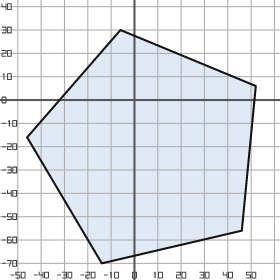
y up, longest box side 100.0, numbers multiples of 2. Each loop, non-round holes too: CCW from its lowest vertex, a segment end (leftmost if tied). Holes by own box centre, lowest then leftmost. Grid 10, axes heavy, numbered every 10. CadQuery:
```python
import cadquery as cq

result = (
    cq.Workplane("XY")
    .moveTo(-14.0, -70.0)
    .lineTo(46.0, -56.0)
    .lineTo(52.0, 6.0)
    .lineTo(-6.0, 30.0)
    .lineTo(-46.0, -16.0)
    .close()
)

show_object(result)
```